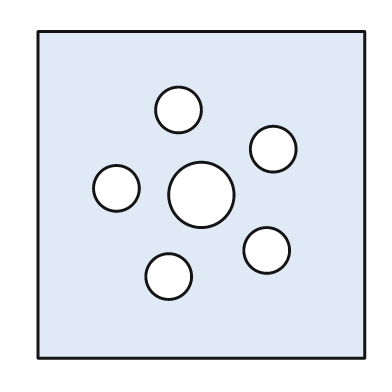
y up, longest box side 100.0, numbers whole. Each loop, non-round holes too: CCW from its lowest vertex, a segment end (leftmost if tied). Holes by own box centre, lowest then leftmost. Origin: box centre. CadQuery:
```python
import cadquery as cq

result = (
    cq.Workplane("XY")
    .moveTo(-50.0, -50.0)
    .lineTo(50.0, -50.0)
    .lineTo(50.0, 50.0)
    .lineTo(-50.0, 50.0)
    .close()
    .moveTo(-10.0, -25.0)
    .circle(7.0)
    .moveTo(20.0, -17.0)
    .circle(7.0)
    .moveTo(0.0, 0.0)
    .circle(10.0)
    .moveTo(-26.0, 2.0)
    .circle(7.0)
    .moveTo(22.0, 14.0)
    .circle(7.0)
    .moveTo(-7.0, 26.0)
    .circle(7.0)
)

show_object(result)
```